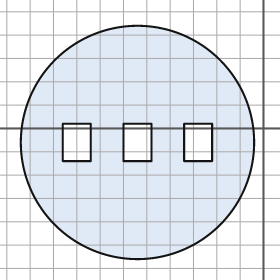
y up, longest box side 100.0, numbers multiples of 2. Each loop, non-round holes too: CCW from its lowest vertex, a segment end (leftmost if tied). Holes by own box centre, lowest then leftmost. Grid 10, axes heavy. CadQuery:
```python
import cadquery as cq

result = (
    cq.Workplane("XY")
    .moveTo(-54.0, -6.0)
    .circle(50.0)
    .moveTo(-86.0, -14.0)
    .lineTo(-74.0, -14.0)
    .lineTo(-74.0, 2.0)
    .lineTo(-86.0, 2.0)
    .close()
    .moveTo(-60.0, -14.0)
    .lineTo(-48.0, -14.0)
    .lineTo(-48.0, 2.0)
    .lineTo(-60.0, 2.0)
    .close()
    .moveTo(-34.0, -14.0)
    .lineTo(-22.0, -14.0)
    .lineTo(-22.0, 2.0)
    .lineTo(-34.0, 2.0)
    .close()
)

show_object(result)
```